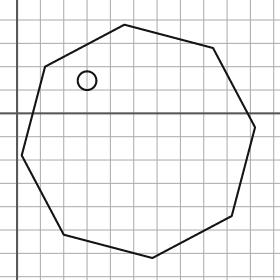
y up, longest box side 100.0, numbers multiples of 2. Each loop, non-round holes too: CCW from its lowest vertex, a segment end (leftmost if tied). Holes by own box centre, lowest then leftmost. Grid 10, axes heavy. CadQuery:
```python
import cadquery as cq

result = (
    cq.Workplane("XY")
    .moveTo(58.0, -62.0)
    .lineTo(92.0, -44.0)
    .lineTo(102.0, -6.0)
    .lineTo(84.0, 28.0)
    .lineTo(46.0, 38.0)
    .lineTo(12.0, 20.0)
    .lineTo(2.0, -18.0)
    .lineTo(20.0, -52.0)
    .close()
    .moveTo(30.0, 14.0)
    .circle(4.0)
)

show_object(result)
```